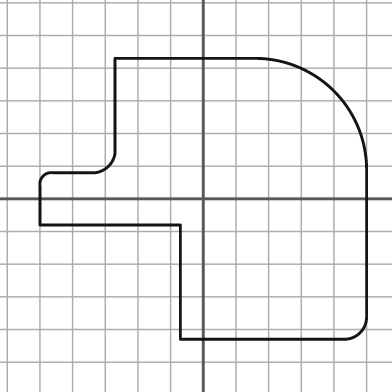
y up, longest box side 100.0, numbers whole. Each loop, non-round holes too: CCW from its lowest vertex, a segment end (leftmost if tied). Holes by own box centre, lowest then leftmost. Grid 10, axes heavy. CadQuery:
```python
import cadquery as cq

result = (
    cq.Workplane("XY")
    .moveTo(-7.0, -43.0)
    .lineTo(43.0, -43.0)
    .threePointArc((48.0, -41.0), (50.0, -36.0))
    .lineTo(50.0, 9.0)
    .threePointArc((40.0, 33.0), (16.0, 43.0))
    .lineTo(-27.0, 43.0)
    .lineTo(-27.0, 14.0)
    .threePointArc((-29.0, 10.0), (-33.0, 8.0))
    .lineTo(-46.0, 8.0)
    .threePointArc((-49.0, 7.0), (-50.0, 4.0))
    .lineTo(-50.0, -8.0)
    .lineTo(-7.0, -8.0)
    .close()
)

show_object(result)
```